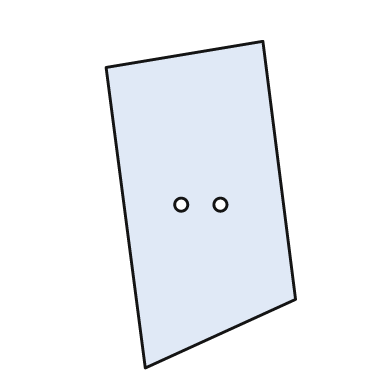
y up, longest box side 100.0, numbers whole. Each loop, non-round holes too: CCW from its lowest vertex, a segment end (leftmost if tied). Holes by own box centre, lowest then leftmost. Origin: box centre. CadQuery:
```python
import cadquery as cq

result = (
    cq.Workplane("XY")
    .moveTo(-17.0, -50.0)
    .lineTo(29.0, -29.0)
    .lineTo(19.0, 50.0)
    .lineTo(-29.0, 42.0)
    .close()
    .moveTo(-6.0, 0.0)
    .circle(2.0)
    .moveTo(6.0, 0.0)
    .circle(2.0)
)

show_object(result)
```